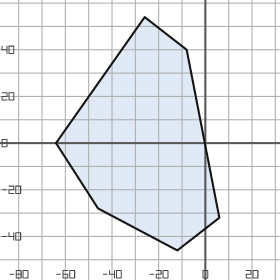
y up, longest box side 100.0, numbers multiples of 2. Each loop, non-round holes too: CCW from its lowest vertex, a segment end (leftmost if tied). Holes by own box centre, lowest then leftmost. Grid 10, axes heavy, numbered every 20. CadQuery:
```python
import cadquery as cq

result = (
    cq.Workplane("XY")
    .moveTo(-12.0, -46.0)
    .lineTo(6.0, -32.0)
    .lineTo(-8.0, 40.0)
    .lineTo(-26.0, 54.0)
    .lineTo(-64.0, 0.0)
    .lineTo(-46.0, -28.0)
    .close()
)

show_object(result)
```